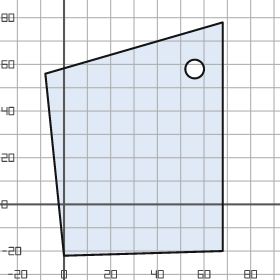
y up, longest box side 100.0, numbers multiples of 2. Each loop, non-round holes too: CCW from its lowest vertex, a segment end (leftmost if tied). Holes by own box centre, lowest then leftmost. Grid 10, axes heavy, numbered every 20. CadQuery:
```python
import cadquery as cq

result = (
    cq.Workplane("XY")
    .moveTo(0.0, -22.0)
    .lineTo(68.0, -20.0)
    .lineTo(68.0, 78.0)
    .lineTo(-8.0, 56.0)
    .close()
    .moveTo(56.0, 58.0)
    .circle(4.0)
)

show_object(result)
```